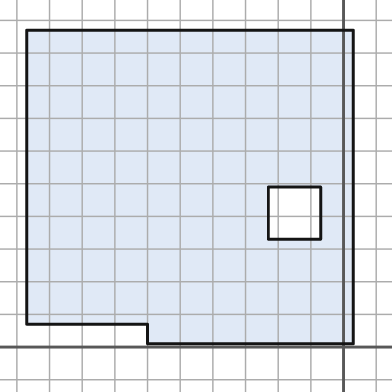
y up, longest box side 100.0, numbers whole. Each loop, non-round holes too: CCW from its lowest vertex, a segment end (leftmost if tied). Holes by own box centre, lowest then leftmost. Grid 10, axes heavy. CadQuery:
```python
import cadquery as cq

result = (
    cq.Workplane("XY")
    .moveTo(-60.0, 1.0)
    .lineTo(3.0, 1.0)
    .lineTo(3.0, 97.0)
    .lineTo(-97.0, 97.0)
    .lineTo(-97.0, 7.0)
    .lineTo(-60.0, 7.0)
    .close()
    .moveTo(-23.0, 33.0)
    .lineTo(-7.0, 33.0)
    .lineTo(-7.0, 49.0)
    .lineTo(-23.0, 49.0)
    .close()
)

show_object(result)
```